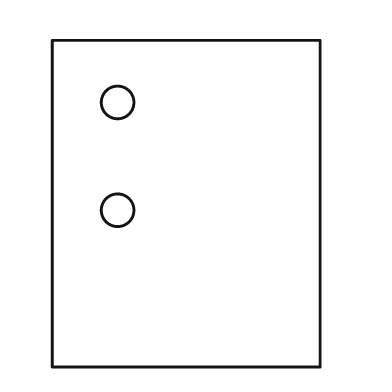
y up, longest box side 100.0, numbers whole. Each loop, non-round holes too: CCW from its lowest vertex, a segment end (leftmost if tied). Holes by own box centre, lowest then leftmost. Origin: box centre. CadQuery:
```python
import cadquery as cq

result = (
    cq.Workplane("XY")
    .moveTo(-41.0, -50.0)
    .lineTo(41.0, -50.0)
    .lineTo(41.0, 50.0)
    .lineTo(-41.0, 50.0)
    .close()
    .moveTo(-21.0, -2.0)
    .circle(5.0)
    .moveTo(-21.0, 31.0)
    .circle(5.0)
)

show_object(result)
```